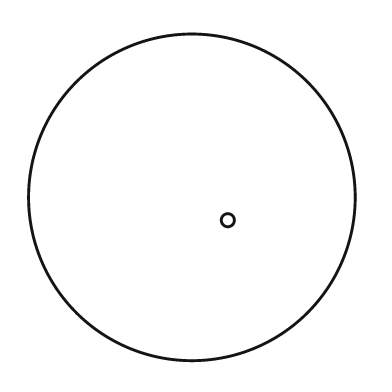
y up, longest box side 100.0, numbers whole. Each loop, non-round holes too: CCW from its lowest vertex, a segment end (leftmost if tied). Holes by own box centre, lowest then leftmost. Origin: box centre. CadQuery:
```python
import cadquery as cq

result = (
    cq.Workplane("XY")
    .moveTo(0.0, 0.0)
    .circle(50.0)
    .moveTo(11.0, -7.0)
    .circle(2.0)
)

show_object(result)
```